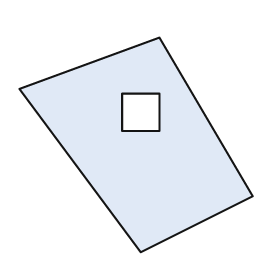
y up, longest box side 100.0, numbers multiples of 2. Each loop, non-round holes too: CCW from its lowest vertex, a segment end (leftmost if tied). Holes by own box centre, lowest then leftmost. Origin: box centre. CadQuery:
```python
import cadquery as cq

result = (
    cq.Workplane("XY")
    .moveTo(2.0, -46.0)
    .lineTo(50.0, -22.0)
    .lineTo(10.0, 46.0)
    .lineTo(-50.0, 24.0)
    .close()
    .moveTo(-6.0, 6.0)
    .lineTo(10.0, 6.0)
    .lineTo(10.0, 22.0)
    .lineTo(-6.0, 22.0)
    .close()
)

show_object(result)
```